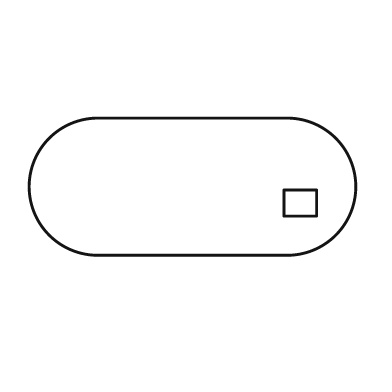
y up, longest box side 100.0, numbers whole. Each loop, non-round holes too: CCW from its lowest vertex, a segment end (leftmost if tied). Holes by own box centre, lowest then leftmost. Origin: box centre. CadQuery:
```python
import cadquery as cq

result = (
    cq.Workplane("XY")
    .moveTo(-29.0, -21.0)
    .lineTo(29.0, -21.0)
    .threePointArc((50.0, 0.0), (29.0, 21.0))
    .lineTo(-29.0, 21.0)
    .threePointArc((-50.0, 0.0), (-29.0, -21.0))
    .close()
    .moveTo(28.0, -9.0)
    .lineTo(38.0, -9.0)
    .lineTo(38.0, -1.0)
    .lineTo(28.0, -1.0)
    .close()
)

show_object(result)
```